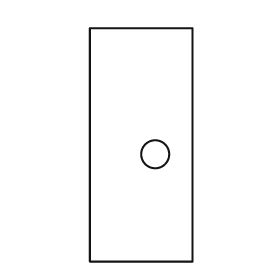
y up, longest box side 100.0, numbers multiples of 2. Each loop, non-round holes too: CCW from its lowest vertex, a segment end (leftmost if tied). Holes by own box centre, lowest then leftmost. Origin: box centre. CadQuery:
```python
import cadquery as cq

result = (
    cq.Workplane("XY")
    .moveTo(-22.0, -50.0)
    .lineTo(22.0, -50.0)
    .lineTo(22.0, 50.0)
    .lineTo(-22.0, 50.0)
    .close()
    .moveTo(6.0, -4.0)
    .circle(6.0)
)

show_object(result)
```